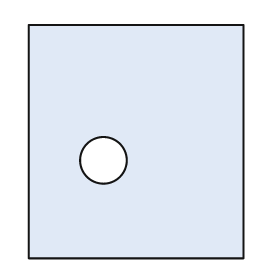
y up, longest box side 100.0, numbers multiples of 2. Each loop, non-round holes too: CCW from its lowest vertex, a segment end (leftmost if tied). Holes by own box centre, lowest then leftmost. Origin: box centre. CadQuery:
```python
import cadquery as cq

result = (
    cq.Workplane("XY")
    .moveTo(-46.0, -50.0)
    .lineTo(46.0, -50.0)
    .lineTo(46.0, 50.0)
    .lineTo(-46.0, 50.0)
    .close()
    .moveTo(-14.0, -8.0)
    .circle(10.0)
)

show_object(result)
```